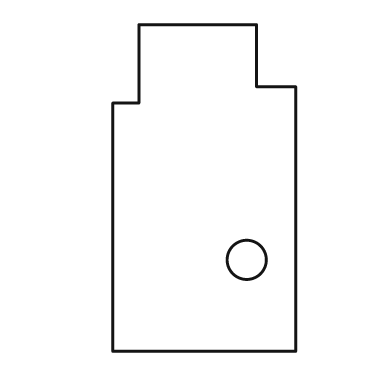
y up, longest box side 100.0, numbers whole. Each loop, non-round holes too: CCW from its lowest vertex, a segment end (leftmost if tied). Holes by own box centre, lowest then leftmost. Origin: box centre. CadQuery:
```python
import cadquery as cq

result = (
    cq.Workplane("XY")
    .moveTo(-28.0, -50.0)
    .lineTo(28.0, -50.0)
    .lineTo(28.0, 31.0)
    .lineTo(16.0, 31.0)
    .lineTo(16.0, 50.0)
    .lineTo(-20.0, 50.0)
    .lineTo(-20.0, 26.0)
    .lineTo(-28.0, 26.0)
    .close()
    .moveTo(13.0, -22.0)
    .circle(6.0)
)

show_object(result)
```